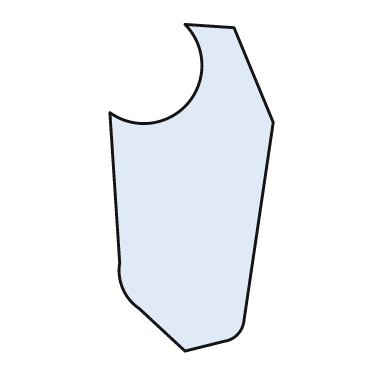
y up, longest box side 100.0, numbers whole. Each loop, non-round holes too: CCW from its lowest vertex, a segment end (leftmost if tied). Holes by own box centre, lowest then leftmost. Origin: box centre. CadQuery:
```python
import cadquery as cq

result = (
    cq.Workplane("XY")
    .moveTo(-2.0, -50.0)
    .lineTo(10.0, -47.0)
    .threePointArc((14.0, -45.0), (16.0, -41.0))
    .lineTo(25.0, 20.0)
    .lineTo(13.0, 49.0)
    .lineTo(-2.0, 50.0)
    .threePointArc((-1.0, 26.0), (-25.0, 23.0))
    .lineTo(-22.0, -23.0)
    .threePointArc((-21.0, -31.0), (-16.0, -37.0))
    .close()
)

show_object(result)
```